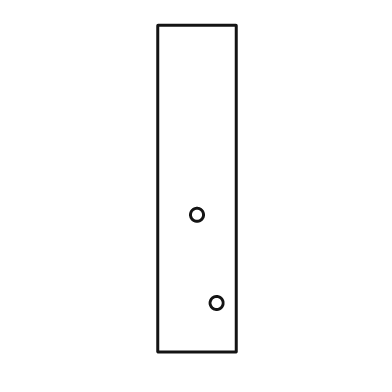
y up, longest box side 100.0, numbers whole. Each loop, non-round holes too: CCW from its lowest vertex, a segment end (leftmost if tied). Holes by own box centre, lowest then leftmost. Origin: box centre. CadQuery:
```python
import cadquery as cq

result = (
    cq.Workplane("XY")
    .moveTo(-12.0, -50.0)
    .lineTo(12.0, -50.0)
    .lineTo(12.0, 50.0)
    .lineTo(-12.0, 50.0)
    .close()
    .moveTo(6.0, -35.0)
    .circle(2.0)
    .moveTo(0.0, -8.0)
    .circle(2.0)
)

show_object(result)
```